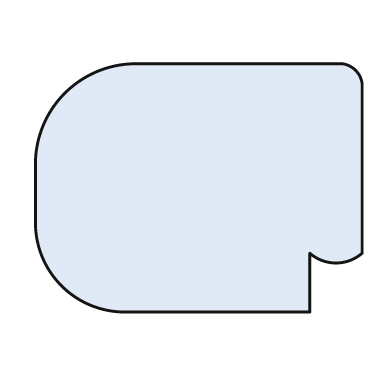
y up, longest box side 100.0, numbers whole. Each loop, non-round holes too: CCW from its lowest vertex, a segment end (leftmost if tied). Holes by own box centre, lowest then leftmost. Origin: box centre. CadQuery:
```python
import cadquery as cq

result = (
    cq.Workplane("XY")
    .moveTo(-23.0, -38.0)
    .lineTo(34.0, -38.0)
    .lineTo(34.0, -20.0)
    .threePointArc((42.0, -23.0), (50.0, -20.0))
    .lineTo(50.0, 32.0)
    .threePointArc((48.0, 36.0), (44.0, 38.0))
    .lineTo(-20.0, 38.0)
    .threePointArc((-41.0, 29.0), (-50.0, 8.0))
    .lineTo(-50.0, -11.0)
    .threePointArc((-42.0, -30.0), (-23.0, -38.0))
    .close()
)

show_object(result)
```